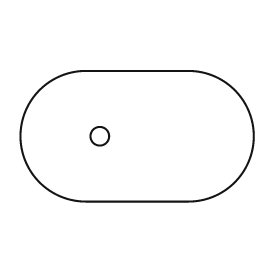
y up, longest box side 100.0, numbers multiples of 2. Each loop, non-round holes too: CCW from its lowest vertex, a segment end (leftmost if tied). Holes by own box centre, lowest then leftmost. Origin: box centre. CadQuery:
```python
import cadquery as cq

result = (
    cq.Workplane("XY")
    .moveTo(-22.0, -28.0)
    .lineTo(22.0, -28.0)
    .threePointArc((50.0, 0.0), (22.0, 28.0))
    .lineTo(-22.0, 28.0)
    .threePointArc((-50.0, 0.0), (-22.0, -28.0))
    .close()
    .moveTo(-16.0, 0.0)
    .circle(4.0)
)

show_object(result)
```